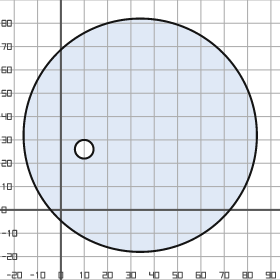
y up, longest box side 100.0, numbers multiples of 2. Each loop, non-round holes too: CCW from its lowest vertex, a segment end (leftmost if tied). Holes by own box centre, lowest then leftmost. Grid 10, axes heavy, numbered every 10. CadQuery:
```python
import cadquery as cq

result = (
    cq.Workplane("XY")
    .moveTo(34.0, 32.0)
    .circle(50.0)
    .moveTo(10.0, 26.0)
    .circle(4.0)
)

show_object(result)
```